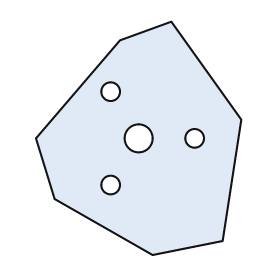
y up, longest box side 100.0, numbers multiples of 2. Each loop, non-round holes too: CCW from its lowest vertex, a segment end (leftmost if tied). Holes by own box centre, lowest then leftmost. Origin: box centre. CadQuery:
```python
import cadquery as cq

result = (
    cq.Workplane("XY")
    .moveTo(6.0, -50.0)
    .lineTo(36.0, -44.0)
    .lineTo(44.0, 8.0)
    .lineTo(14.0, 50.0)
    .lineTo(-8.0, 42.0)
    .lineTo(-44.0, 0.0)
    .lineTo(-36.0, -26.0)
    .close()
    .moveTo(-12.0, -20.0)
    .circle(4.0)
    .moveTo(0.0, 0.0)
    .circle(6.0)
    .moveTo(24.0, 0.0)
    .circle(4.0)
    .moveTo(-12.0, 20.0)
    .circle(4.0)
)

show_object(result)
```